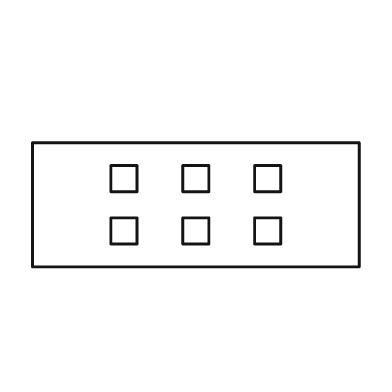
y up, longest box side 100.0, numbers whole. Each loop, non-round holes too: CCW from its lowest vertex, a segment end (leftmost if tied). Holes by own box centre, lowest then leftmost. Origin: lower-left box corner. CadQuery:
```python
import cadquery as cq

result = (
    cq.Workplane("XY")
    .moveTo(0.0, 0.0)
    .lineTo(100.0, 0.0)
    .lineTo(100.0, 38.0)
    .lineTo(0.0, 38.0)
    .close()
    .moveTo(24.0, 7.0)
    .lineTo(32.0, 7.0)
    .lineTo(32.0, 15.0)
    .lineTo(24.0, 15.0)
    .close()
    .moveTo(46.0, 7.0)
    .lineTo(54.0, 7.0)
    .lineTo(54.0, 15.0)
    .lineTo(46.0, 15.0)
    .close()
    .moveTo(68.0, 7.0)
    .lineTo(76.0, 7.0)
    .lineTo(76.0, 15.0)
    .lineTo(68.0, 15.0)
    .close()
    .moveTo(24.0, 23.0)
    .lineTo(32.0, 23.0)
    .lineTo(32.0, 31.0)
    .lineTo(24.0, 31.0)
    .close()
    .moveTo(46.0, 23.0)
    .lineTo(54.0, 23.0)
    .lineTo(54.0, 31.0)
    .lineTo(46.0, 31.0)
    .close()
    .moveTo(68.0, 23.0)
    .lineTo(76.0, 23.0)
    .lineTo(76.0, 31.0)
    .lineTo(68.0, 31.0)
    .close()
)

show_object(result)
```